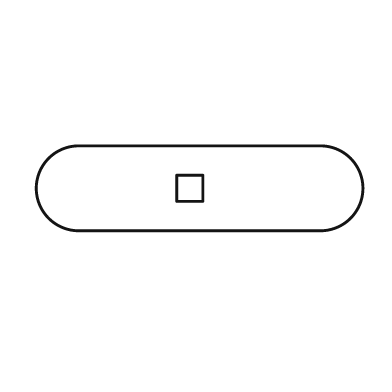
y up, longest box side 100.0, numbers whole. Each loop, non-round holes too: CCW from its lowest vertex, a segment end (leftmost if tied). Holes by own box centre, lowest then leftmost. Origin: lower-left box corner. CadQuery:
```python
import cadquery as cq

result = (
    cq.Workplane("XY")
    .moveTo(13.0, 0.0)
    .lineTo(87.0, 0.0)
    .threePointArc((100.0, 13.0), (87.0, 26.0))
    .lineTo(13.0, 26.0)
    .threePointArc((0.0, 13.0), (13.0, 0.0))
    .close()
    .moveTo(43.0, 9.0)
    .lineTo(51.0, 9.0)
    .lineTo(51.0, 17.0)
    .lineTo(43.0, 17.0)
    .close()
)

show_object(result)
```